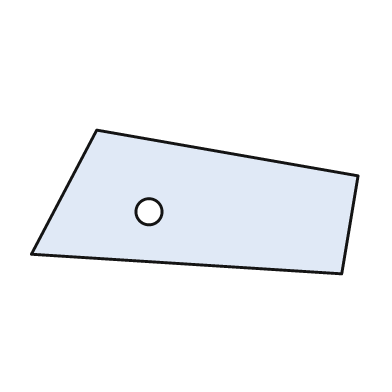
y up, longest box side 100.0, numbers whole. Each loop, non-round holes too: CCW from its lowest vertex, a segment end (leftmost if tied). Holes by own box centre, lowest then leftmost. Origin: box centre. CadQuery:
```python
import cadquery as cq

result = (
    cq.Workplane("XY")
    .moveTo(45.0, -22.0)
    .lineTo(50.0, 8.0)
    .lineTo(-30.0, 22.0)
    .lineTo(-50.0, -16.0)
    .close()
    .moveTo(-14.0, -3.0)
    .circle(4.0)
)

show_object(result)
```